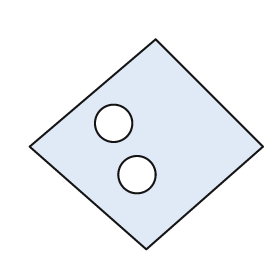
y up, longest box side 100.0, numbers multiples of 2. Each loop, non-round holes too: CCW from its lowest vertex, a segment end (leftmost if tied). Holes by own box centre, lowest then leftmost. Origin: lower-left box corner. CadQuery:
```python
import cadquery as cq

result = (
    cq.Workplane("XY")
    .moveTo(50.0, 0.0)
    .lineTo(100.0, 44.0)
    .lineTo(54.0, 90.0)
    .lineTo(0.0, 44.0)
    .close()
    .moveTo(46.0, 32.0)
    .circle(8.0)
    .moveTo(36.0, 54.0)
    .circle(8.0)
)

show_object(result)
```